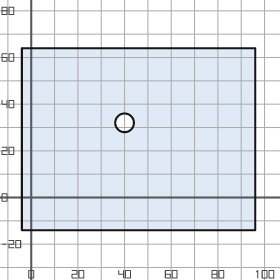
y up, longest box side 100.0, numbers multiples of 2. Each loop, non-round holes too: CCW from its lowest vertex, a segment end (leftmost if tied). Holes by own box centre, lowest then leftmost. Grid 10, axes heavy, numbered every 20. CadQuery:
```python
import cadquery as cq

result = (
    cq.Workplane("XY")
    .moveTo(-4.0, -14.0)
    .lineTo(96.0, -14.0)
    .lineTo(96.0, 64.0)
    .lineTo(-4.0, 64.0)
    .close()
    .moveTo(40.0, 32.0)
    .circle(4.0)
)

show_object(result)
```